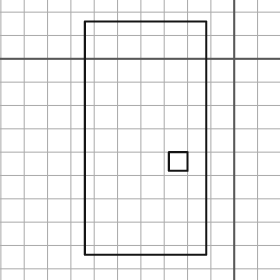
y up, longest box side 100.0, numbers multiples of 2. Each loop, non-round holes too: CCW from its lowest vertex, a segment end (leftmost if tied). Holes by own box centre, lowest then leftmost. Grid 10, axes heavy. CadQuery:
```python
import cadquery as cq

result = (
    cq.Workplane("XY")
    .moveTo(-64.0, -84.0)
    .lineTo(-12.0, -84.0)
    .lineTo(-12.0, 16.0)
    .lineTo(-64.0, 16.0)
    .close()
    .moveTo(-28.0, -48.0)
    .lineTo(-20.0, -48.0)
    .lineTo(-20.0, -40.0)
    .lineTo(-28.0, -40.0)
    .close()
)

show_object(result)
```